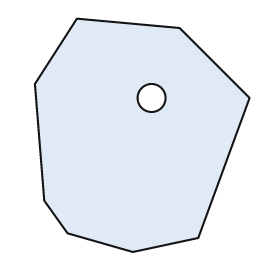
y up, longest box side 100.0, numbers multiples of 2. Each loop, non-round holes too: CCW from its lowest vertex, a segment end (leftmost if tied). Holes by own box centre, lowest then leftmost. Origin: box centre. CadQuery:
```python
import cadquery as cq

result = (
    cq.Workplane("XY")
    .moveTo(-4.0, -50.0)
    .lineTo(24.0, -44.0)
    .lineTo(46.0, 16.0)
    .lineTo(16.0, 46.0)
    .lineTo(-28.0, 50.0)
    .lineTo(-46.0, 22.0)
    .lineTo(-42.0, -28.0)
    .lineTo(-32.0, -42.0)
    .close()
    .moveTo(4.0, 16.0)
    .circle(6.0)
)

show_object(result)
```